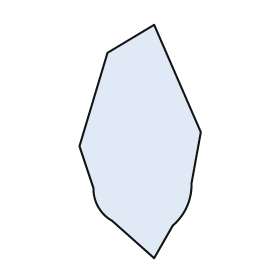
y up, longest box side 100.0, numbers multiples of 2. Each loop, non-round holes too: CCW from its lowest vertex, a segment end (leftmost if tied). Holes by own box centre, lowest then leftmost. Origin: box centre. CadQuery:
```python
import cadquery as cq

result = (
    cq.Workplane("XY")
    .moveTo(6.0, -50.0)
    .lineTo(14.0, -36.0)
    .threePointArc((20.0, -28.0), (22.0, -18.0))
    .lineTo(26.0, 4.0)
    .lineTo(6.0, 50.0)
    .lineTo(-14.0, 38.0)
    .lineTo(-26.0, -2.0)
    .lineTo(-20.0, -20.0)
    .threePointArc((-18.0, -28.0), (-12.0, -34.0))
    .close()
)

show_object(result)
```